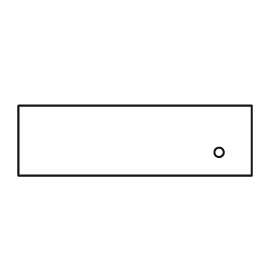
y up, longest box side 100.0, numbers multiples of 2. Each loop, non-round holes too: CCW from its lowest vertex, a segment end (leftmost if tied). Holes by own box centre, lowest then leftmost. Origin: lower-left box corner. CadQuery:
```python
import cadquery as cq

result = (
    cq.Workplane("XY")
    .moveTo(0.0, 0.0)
    .lineTo(100.0, 0.0)
    .lineTo(100.0, 30.0)
    .lineTo(0.0, 30.0)
    .close()
    .moveTo(86.0, 10.0)
    .circle(2.0)
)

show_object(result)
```